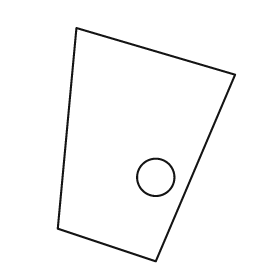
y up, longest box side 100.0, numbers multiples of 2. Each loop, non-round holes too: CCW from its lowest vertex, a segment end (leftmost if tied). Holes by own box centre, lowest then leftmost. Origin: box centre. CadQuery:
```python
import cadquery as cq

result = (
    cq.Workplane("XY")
    .moveTo(4.0, -50.0)
    .lineTo(38.0, 30.0)
    .lineTo(-30.0, 50.0)
    .lineTo(-38.0, -36.0)
    .close()
    .moveTo(4.0, -14.0)
    .circle(8.0)
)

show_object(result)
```